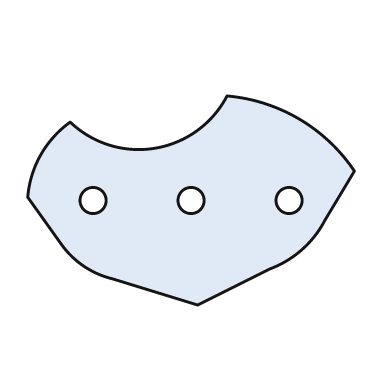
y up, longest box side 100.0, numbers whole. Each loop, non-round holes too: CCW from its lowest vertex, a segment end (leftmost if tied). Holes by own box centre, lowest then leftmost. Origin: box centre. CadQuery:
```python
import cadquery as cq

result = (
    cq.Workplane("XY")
    .moveTo(2.0, -32.0)
    .lineTo(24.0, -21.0)
    .threePointArc((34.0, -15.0), (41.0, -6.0))
    .lineTo(50.0, 9.0)
    .threePointArc((33.0, 25.0), (11.0, 32.0))
    .threePointArc((-11.0, 16.0), (-37.0, 24.0))
    .threePointArc((-46.0, 14.0), (-50.0, 1.0))
    .lineTo(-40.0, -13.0)
    .threePointArc((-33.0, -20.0), (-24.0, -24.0))
    .close()
    .moveTo(-30.0, 0.0)
    .circle(4.0)
    .moveTo(0.0, 0.0)
    .circle(4.0)
    .moveTo(30.0, 0.0)
    .circle(4.0)
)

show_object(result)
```